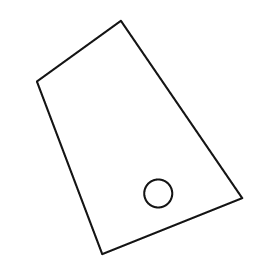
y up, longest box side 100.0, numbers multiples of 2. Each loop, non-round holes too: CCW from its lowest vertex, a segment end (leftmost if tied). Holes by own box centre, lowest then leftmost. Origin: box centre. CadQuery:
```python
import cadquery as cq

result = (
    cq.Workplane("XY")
    .moveTo(-16.0, -50.0)
    .lineTo(44.0, -26.0)
    .lineTo(-8.0, 50.0)
    .lineTo(-44.0, 24.0)
    .close()
    .moveTo(8.0, -24.0)
    .circle(6.0)
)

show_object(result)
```